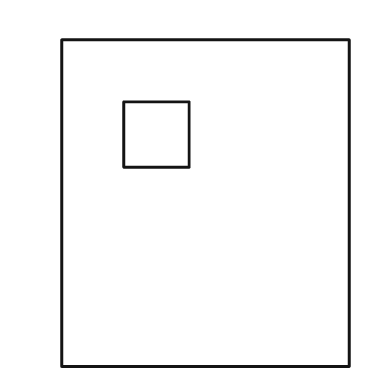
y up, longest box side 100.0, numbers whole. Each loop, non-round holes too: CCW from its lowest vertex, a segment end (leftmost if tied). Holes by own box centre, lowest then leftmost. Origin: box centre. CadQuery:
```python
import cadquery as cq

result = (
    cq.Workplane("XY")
    .moveTo(-44.0, -50.0)
    .lineTo(44.0, -50.0)
    .lineTo(44.0, 50.0)
    .lineTo(-44.0, 50.0)
    .close()
    .moveTo(-25.0, 11.0)
    .lineTo(-5.0, 11.0)
    .lineTo(-5.0, 31.0)
    .lineTo(-25.0, 31.0)
    .close()
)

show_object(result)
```